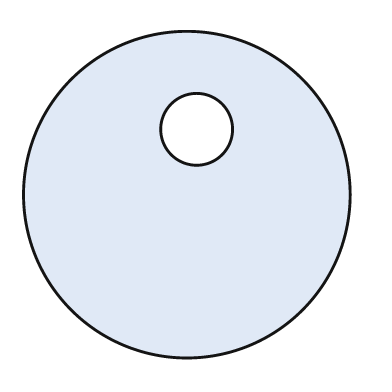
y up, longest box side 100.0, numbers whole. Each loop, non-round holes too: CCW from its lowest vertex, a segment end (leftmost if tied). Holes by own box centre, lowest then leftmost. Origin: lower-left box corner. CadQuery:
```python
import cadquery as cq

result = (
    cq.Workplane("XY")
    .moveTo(50.0, 50.0)
    .circle(50.0)
    .moveTo(53.0, 70.0)
    .circle(11.0)
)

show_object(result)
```